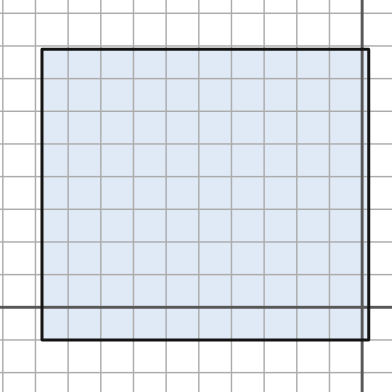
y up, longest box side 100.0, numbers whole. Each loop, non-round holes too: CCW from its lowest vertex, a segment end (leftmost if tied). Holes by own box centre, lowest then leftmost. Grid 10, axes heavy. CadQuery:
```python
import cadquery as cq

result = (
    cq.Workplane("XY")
    .moveTo(-98.0, -10.0)
    .lineTo(2.0, -10.0)
    .lineTo(2.0, 79.0)
    .lineTo(-98.0, 79.0)
    .close()
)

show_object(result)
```